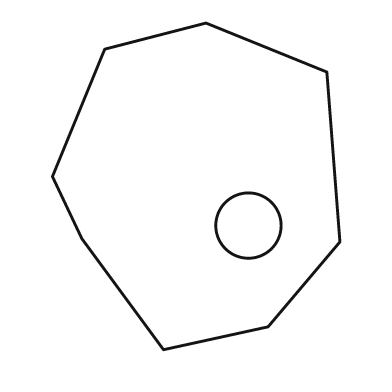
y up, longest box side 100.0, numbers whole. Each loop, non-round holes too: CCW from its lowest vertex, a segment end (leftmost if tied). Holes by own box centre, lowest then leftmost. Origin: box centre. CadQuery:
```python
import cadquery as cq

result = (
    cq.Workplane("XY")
    .moveTo(-10.0, -50.0)
    .lineTo(22.0, -43.0)
    .lineTo(44.0, -17.0)
    .lineTo(40.0, 35.0)
    .lineTo(3.0, 50.0)
    .lineTo(-28.0, 42.0)
    .lineTo(-44.0, 3.0)
    .lineTo(-35.0, -16.0)
    .close()
    .moveTo(16.0, -12.0)
    .circle(10.0)
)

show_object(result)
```